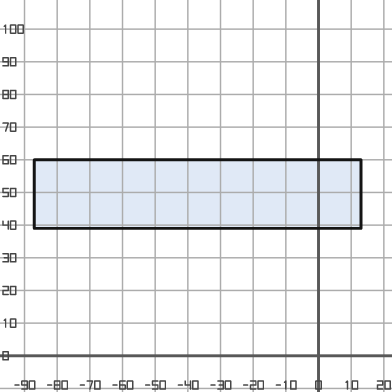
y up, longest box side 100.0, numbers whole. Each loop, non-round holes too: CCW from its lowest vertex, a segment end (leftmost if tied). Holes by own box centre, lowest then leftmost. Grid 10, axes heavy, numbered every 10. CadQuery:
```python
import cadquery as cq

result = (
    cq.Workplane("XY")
    .moveTo(-87.0, 39.0)
    .lineTo(13.0, 39.0)
    .lineTo(13.0, 60.0)
    .lineTo(-87.0, 60.0)
    .close()
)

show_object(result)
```